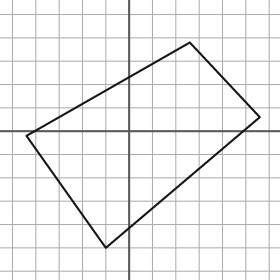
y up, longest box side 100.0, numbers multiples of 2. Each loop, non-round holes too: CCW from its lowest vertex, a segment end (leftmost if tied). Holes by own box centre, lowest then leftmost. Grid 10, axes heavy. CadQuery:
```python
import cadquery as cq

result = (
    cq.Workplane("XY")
    .moveTo(-10.0, -50.0)
    .lineTo(56.0, 6.0)
    .lineTo(26.0, 38.0)
    .lineTo(-44.0, -2.0)
    .close()
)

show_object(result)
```